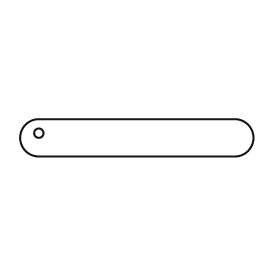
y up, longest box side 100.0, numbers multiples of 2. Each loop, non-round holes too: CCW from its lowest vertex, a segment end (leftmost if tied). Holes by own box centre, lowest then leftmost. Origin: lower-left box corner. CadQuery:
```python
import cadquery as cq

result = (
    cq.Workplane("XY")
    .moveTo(8.0, 0.0)
    .lineTo(92.0, 0.0)
    .threePointArc((100.0, 8.0), (92.0, 16.0))
    .lineTo(8.0, 16.0)
    .threePointArc((0.0, 8.0), (8.0, 0.0))
    .close()
    .moveTo(8.0, 10.0)
    .circle(2.0)
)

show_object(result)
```